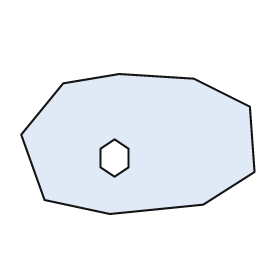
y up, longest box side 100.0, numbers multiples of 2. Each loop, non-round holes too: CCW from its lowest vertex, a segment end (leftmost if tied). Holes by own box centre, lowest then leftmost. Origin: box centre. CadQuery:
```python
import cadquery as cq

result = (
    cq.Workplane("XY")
    .moveTo(-12.0, -30.0)
    .lineTo(28.0, -26.0)
    .lineTo(50.0, -12.0)
    .lineTo(48.0, 16.0)
    .lineTo(24.0, 28.0)
    .lineTo(-8.0, 30.0)
    .lineTo(-32.0, 26.0)
    .lineTo(-50.0, 4.0)
    .lineTo(-40.0, -24.0)
    .close()
    .moveTo(-10.0, -14.0)
    .lineTo(-4.0, -10.0)
    .lineTo(-4.0, -2.0)
    .lineTo(-10.0, 2.0)
    .lineTo(-16.0, -2.0)
    .lineTo(-16.0, -10.0)
    .close()
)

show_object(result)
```